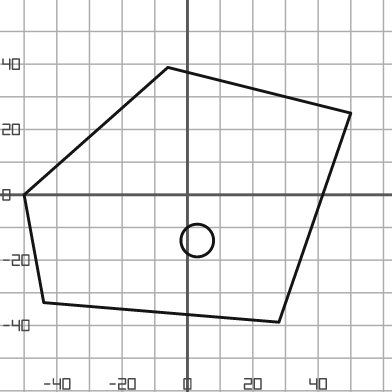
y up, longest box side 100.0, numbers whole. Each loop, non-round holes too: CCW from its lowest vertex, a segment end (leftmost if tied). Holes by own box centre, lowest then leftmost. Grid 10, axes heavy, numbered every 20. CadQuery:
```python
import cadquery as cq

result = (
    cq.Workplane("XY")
    .moveTo(28.0, -39.0)
    .lineTo(50.0, 25.0)
    .lineTo(-6.0, 39.0)
    .lineTo(-50.0, 0.0)
    .lineTo(-44.0, -33.0)
    .close()
    .moveTo(3.0, -14.0)
    .circle(5.0)
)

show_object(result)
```